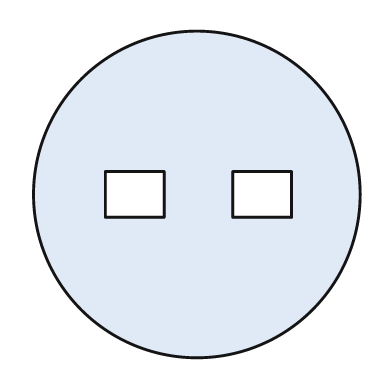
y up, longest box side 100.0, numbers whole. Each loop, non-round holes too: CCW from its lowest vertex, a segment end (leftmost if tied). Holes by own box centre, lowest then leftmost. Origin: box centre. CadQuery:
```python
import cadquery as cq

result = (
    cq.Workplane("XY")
    .moveTo(0.0, 0.0)
    .circle(50.0)
    .moveTo(-28.0, -7.0)
    .lineTo(-10.0, -7.0)
    .lineTo(-10.0, 7.0)
    .lineTo(-28.0, 7.0)
    .close()
    .moveTo(11.0, -7.0)
    .lineTo(29.0, -7.0)
    .lineTo(29.0, 7.0)
    .lineTo(11.0, 7.0)
    .close()
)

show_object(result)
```